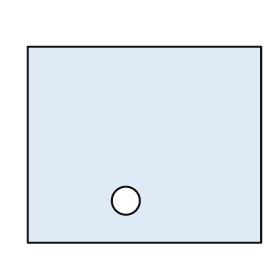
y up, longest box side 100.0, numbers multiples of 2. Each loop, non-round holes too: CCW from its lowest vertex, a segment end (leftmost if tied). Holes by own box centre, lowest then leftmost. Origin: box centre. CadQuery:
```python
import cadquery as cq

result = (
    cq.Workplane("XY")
    .moveTo(-50.0, -42.0)
    .lineTo(50.0, -42.0)
    .lineTo(50.0, 42.0)
    .lineTo(-50.0, 42.0)
    .close()
    .moveTo(-8.0, -24.0)
    .circle(6.0)
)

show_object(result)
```